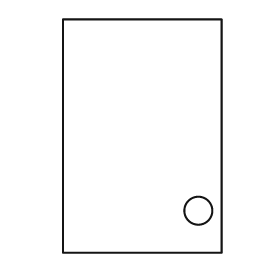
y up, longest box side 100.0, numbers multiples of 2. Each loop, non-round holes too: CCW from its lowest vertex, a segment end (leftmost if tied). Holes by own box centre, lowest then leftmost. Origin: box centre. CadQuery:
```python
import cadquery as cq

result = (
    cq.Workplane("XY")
    .moveTo(-34.0, -50.0)
    .lineTo(34.0, -50.0)
    .lineTo(34.0, 50.0)
    .lineTo(-34.0, 50.0)
    .close()
    .moveTo(24.0, -32.0)
    .circle(6.0)
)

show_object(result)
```